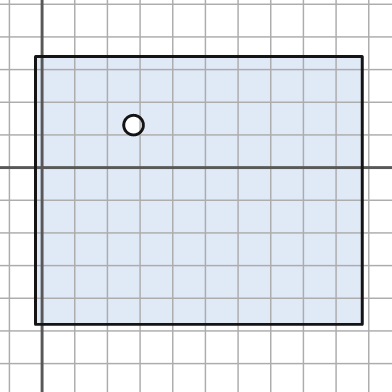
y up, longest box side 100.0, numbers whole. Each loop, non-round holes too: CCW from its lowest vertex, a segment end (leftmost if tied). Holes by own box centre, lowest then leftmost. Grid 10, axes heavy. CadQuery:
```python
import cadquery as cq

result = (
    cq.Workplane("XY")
    .moveTo(-2.0, -48.0)
    .lineTo(98.0, -48.0)
    .lineTo(98.0, 34.0)
    .lineTo(-2.0, 34.0)
    .close()
    .moveTo(28.0, 13.0)
    .circle(3.0)
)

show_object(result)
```